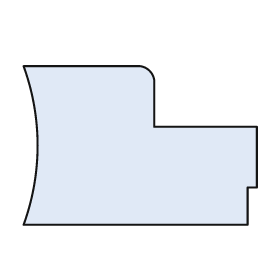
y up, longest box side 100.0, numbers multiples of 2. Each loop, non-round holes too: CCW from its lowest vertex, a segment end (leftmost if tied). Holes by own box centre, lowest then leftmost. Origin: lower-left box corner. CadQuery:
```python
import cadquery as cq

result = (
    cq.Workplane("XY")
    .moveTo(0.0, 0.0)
    .lineTo(96.0, 0.0)
    .lineTo(96.0, 16.0)
    .lineTo(100.0, 16.0)
    .lineTo(100.0, 42.0)
    .lineTo(56.0, 42.0)
    .lineTo(56.0, 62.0)
    .threePointArc((54.0, 66.0), (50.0, 68.0))
    .lineTo(0.0, 68.0)
    .threePointArc((6.0, 34.0), (0.0, 0.0))
    .close()
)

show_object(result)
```